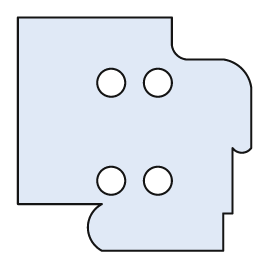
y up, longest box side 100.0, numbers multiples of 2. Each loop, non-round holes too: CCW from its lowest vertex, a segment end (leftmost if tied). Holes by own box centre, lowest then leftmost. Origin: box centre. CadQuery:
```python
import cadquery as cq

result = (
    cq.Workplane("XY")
    .moveTo(-14.0, -50.0)
    .lineTo(38.0, -50.0)
    .lineTo(38.0, -34.0)
    .lineTo(42.0, -34.0)
    .lineTo(42.0, -6.0)
    .threePointArc((46.0, -8.0), (50.0, -6.0))
    .lineTo(50.0, 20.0)
    .threePointArc((46.0, 28.0), (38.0, 32.0))
    .lineTo(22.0, 32.0)
    .threePointArc((18.0, 34.0), (16.0, 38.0))
    .lineTo(16.0, 50.0)
    .lineTo(-50.0, 50.0)
    .lineTo(-50.0, -30.0)
    .lineTo(-14.0, -30.0)
    .threePointArc((-20.0, -40.0), (-14.0, -50.0))
    .close()
    .moveTo(-10.0, -20.0)
    .circle(6.0)
    .moveTo(10.0, -20.0)
    .circle(6.0)
    .moveTo(-10.0, 22.0)
    .circle(6.0)
    .moveTo(10.0, 22.0)
    .circle(6.0)
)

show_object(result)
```